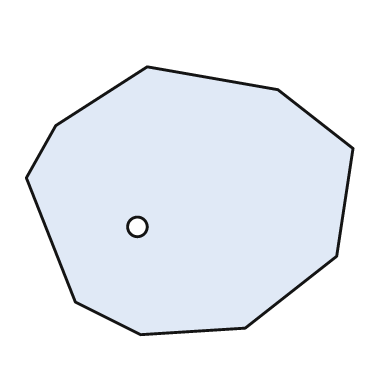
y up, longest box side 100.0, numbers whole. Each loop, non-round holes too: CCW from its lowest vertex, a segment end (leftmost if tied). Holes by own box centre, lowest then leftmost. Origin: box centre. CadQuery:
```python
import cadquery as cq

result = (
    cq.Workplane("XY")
    .moveTo(-15.0, -41.0)
    .lineTo(17.0, -39.0)
    .lineTo(45.0, -17.0)
    .lineTo(50.0, 16.0)
    .lineTo(27.0, 34.0)
    .lineTo(-13.0, 41.0)
    .lineTo(-41.0, 23.0)
    .lineTo(-50.0, 7.0)
    .lineTo(-35.0, -31.0)
    .close()
    .moveTo(-16.0, -8.0)
    .circle(3.0)
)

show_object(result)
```